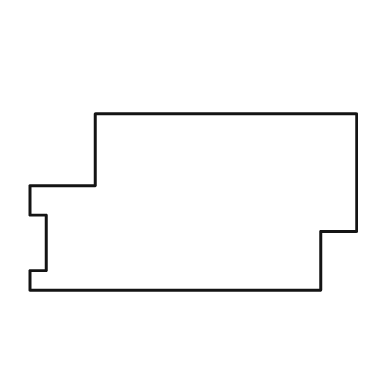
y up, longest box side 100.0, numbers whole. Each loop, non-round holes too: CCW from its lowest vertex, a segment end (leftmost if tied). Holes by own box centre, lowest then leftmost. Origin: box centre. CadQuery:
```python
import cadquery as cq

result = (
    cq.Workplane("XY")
    .moveTo(-50.0, -27.0)
    .lineTo(39.0, -27.0)
    .lineTo(39.0, -9.0)
    .lineTo(50.0, -9.0)
    .lineTo(50.0, 27.0)
    .lineTo(-30.0, 27.0)
    .lineTo(-30.0, 5.0)
    .lineTo(-50.0, 5.0)
    .lineTo(-50.0, -4.0)
    .lineTo(-45.0, -4.0)
    .lineTo(-45.0, -21.0)
    .lineTo(-50.0, -21.0)
    .close()
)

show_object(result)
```